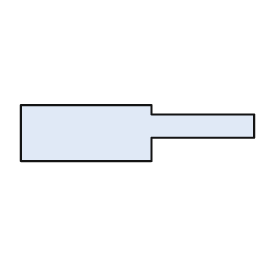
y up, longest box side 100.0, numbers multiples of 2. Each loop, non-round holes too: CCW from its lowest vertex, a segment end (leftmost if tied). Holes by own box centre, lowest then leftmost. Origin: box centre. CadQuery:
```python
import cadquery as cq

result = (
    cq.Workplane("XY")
    .moveTo(-50.0, -12.0)
    .lineTo(6.0, -12.0)
    .lineTo(6.0, -2.0)
    .lineTo(50.0, -2.0)
    .lineTo(50.0, 8.0)
    .lineTo(6.0, 8.0)
    .lineTo(6.0, 12.0)
    .lineTo(-50.0, 12.0)
    .close()
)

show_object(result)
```